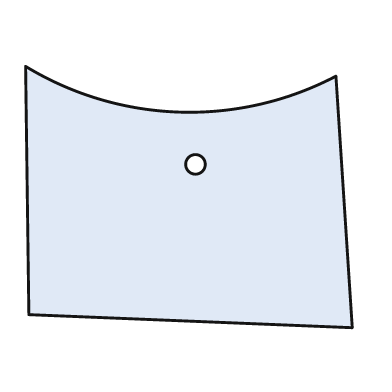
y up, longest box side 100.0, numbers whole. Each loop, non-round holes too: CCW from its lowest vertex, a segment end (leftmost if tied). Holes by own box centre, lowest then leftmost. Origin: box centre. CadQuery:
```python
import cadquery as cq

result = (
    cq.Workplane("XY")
    .moveTo(50.0, -40.0)
    .lineTo(45.0, 37.0)
    .threePointArc((-3.0, 26.0), (-50.0, 40.0))
    .lineTo(-49.0, -36.0)
    .close()
    .moveTo(2.0, 10.0)
    .circle(3.0)
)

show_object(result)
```